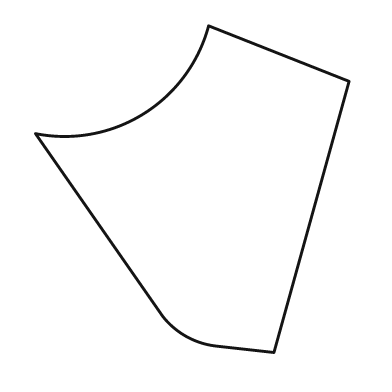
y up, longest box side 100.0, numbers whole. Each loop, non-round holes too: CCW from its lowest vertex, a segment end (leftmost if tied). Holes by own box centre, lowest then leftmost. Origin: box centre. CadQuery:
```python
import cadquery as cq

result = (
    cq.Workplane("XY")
    .moveTo(25.0, -50.0)
    .lineTo(48.0, 33.0)
    .lineTo(5.0, 50.0)
    .threePointArc((-15.0, 23.0), (-48.0, 17.0))
    .lineTo(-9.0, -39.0)
    .threePointArc((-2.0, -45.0), (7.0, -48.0))
    .close()
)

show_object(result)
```